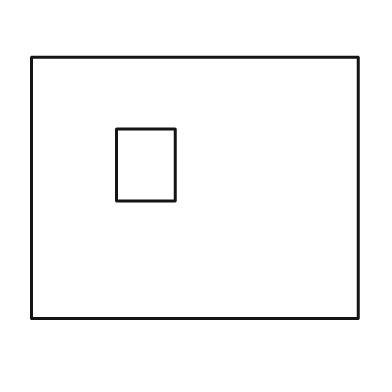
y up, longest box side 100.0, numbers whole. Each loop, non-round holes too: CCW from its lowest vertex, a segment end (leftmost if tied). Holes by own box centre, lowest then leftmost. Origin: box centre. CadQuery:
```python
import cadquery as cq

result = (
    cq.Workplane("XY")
    .moveTo(-50.0, -40.0)
    .lineTo(50.0, -40.0)
    .lineTo(50.0, 40.0)
    .lineTo(-50.0, 40.0)
    .close()
    .moveTo(-24.0, -4.0)
    .lineTo(-6.0, -4.0)
    .lineTo(-6.0, 18.0)
    .lineTo(-24.0, 18.0)
    .close()
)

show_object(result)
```